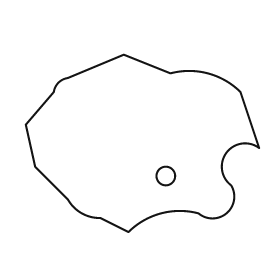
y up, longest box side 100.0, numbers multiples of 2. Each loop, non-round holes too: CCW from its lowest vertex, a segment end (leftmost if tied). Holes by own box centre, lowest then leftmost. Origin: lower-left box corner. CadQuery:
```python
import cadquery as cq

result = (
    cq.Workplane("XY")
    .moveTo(44.0, 0.0)
    .threePointArc((58.0, 8.0), (74.0, 8.0))
    .threePointArc((86.0, 8.0), (88.0, 20.0))
    .threePointArc((86.0, 34.0), (100.0, 36.0))
    .lineTo(92.0, 60.0)
    .threePointArc((78.0, 68.0), (62.0, 68.0))
    .lineTo(42.0, 76.0)
    .lineTo(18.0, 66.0)
    .threePointArc((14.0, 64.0), (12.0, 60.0))
    .lineTo(0.0, 46.0)
    .lineTo(4.0, 28.0)
    .lineTo(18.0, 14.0)
    .threePointArc((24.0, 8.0), (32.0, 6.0))
    .close()
    .moveTo(60.0, 24.0)
    .circle(4.0)
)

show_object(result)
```